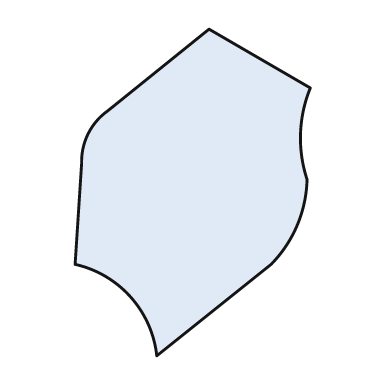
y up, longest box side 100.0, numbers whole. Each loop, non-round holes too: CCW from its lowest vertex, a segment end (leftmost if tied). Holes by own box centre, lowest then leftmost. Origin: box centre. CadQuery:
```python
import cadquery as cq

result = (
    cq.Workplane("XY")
    .moveTo(-11.0, -50.0)
    .lineTo(24.0, -22.0)
    .threePointArc((32.0, -10.0), (35.0, 4.0))
    .threePointArc((33.0, 18.0), (36.0, 32.0))
    .lineTo(5.0, 50.0)
    .lineTo(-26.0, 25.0)
    .threePointArc((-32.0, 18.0), (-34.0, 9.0))
    .lineTo(-36.0, -22.0)
    .threePointArc((-19.0, -32.0), (-11.0, -50.0))
    .close()
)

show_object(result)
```